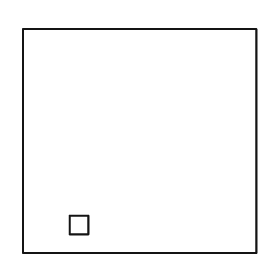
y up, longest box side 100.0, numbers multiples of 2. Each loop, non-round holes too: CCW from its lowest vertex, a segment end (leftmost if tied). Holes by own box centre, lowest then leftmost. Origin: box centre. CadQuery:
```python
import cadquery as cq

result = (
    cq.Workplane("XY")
    .moveTo(-50.0, -48.0)
    .lineTo(50.0, -48.0)
    .lineTo(50.0, 48.0)
    .lineTo(-50.0, 48.0)
    .close()
    .moveTo(-30.0, -40.0)
    .lineTo(-22.0, -40.0)
    .lineTo(-22.0, -32.0)
    .lineTo(-30.0, -32.0)
    .close()
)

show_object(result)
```